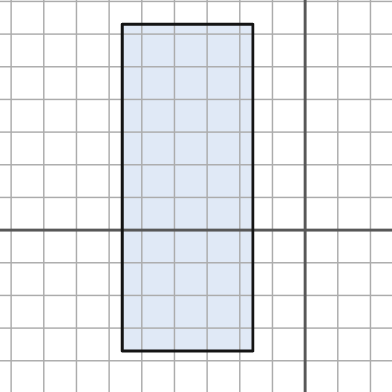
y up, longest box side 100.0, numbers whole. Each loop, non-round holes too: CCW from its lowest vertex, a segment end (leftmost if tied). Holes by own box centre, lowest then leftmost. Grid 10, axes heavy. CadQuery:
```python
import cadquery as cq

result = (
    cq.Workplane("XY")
    .moveTo(-56.0, -37.0)
    .lineTo(-16.0, -37.0)
    .lineTo(-16.0, 63.0)
    .lineTo(-56.0, 63.0)
    .close()
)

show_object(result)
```